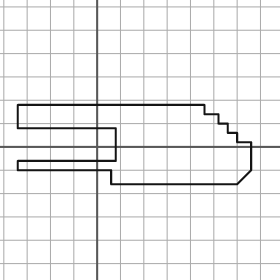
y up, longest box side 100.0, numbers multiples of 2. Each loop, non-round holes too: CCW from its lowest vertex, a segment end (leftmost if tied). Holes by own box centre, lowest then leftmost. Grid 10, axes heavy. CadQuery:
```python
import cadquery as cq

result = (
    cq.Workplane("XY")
    .moveTo(6.0, -16.0)
    .lineTo(60.0, -16.0)
    .lineTo(66.0, -10.0)
    .lineTo(66.0, 2.0)
    .lineTo(60.0, 2.0)
    .lineTo(60.0, 6.0)
    .lineTo(56.0, 6.0)
    .lineTo(56.0, 10.0)
    .lineTo(52.0, 10.0)
    .lineTo(52.0, 14.0)
    .lineTo(46.0, 14.0)
    .lineTo(46.0, 18.0)
    .lineTo(-34.0, 18.0)
    .lineTo(-34.0, 8.0)
    .lineTo(8.0, 8.0)
    .lineTo(8.0, -6.0)
    .lineTo(-34.0, -6.0)
    .lineTo(-34.0, -10.0)
    .lineTo(6.0, -10.0)
    .close()
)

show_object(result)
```